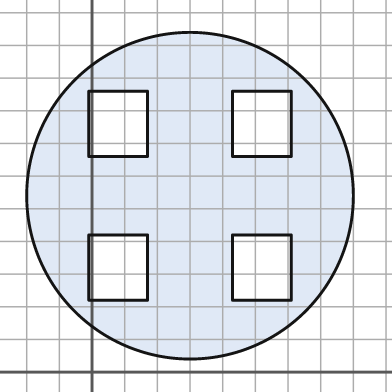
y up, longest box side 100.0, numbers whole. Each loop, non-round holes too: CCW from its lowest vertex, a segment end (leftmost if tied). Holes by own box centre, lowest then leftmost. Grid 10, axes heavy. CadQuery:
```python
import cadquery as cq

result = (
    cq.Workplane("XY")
    .moveTo(30.0, 54.0)
    .circle(50.0)
    .moveTo(-1.0, 22.0)
    .lineTo(17.0, 22.0)
    .lineTo(17.0, 42.0)
    .lineTo(-1.0, 42.0)
    .close()
    .moveTo(43.0, 22.0)
    .lineTo(61.0, 22.0)
    .lineTo(61.0, 42.0)
    .lineTo(43.0, 42.0)
    .close()
    .moveTo(-1.0, 66.0)
    .lineTo(17.0, 66.0)
    .lineTo(17.0, 86.0)
    .lineTo(-1.0, 86.0)
    .close()
    .moveTo(43.0, 66.0)
    .lineTo(61.0, 66.0)
    .lineTo(61.0, 86.0)
    .lineTo(43.0, 86.0)
    .close()
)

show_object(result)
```